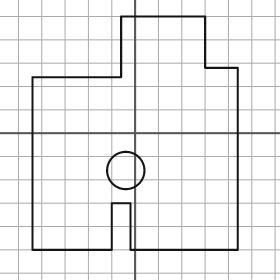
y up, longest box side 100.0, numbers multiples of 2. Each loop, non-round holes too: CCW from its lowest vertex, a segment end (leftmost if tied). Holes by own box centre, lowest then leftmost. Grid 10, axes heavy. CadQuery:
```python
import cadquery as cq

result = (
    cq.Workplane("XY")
    .moveTo(-44.0, -50.0)
    .lineTo(-10.0, -50.0)
    .lineTo(-10.0, -30.0)
    .lineTo(-2.0, -30.0)
    .lineTo(-2.0, -50.0)
    .lineTo(44.0, -50.0)
    .lineTo(44.0, 28.0)
    .lineTo(30.0, 28.0)
    .lineTo(30.0, 50.0)
    .lineTo(-6.0, 50.0)
    .lineTo(-6.0, 24.0)
    .lineTo(-44.0, 24.0)
    .close()
    .moveTo(-4.0, -16.0)
    .circle(8.0)
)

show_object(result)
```